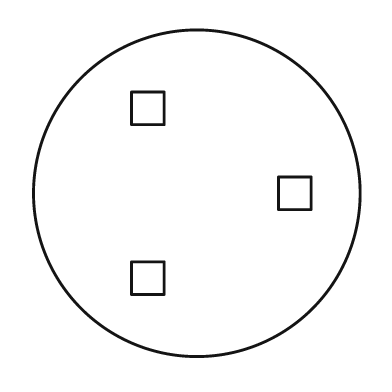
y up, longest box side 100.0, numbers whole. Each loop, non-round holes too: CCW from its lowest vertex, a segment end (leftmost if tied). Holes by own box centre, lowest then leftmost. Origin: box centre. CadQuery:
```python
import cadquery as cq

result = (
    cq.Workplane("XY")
    .moveTo(0.0, 0.0)
    .circle(50.0)
    .moveTo(-20.0, -31.0)
    .lineTo(-10.0, -31.0)
    .lineTo(-10.0, -21.0)
    .lineTo(-20.0, -21.0)
    .close()
    .moveTo(25.0, -5.0)
    .lineTo(35.0, -5.0)
    .lineTo(35.0, 5.0)
    .lineTo(25.0, 5.0)
    .close()
    .moveTo(-20.0, 21.0)
    .lineTo(-10.0, 21.0)
    .lineTo(-10.0, 31.0)
    .lineTo(-20.0, 31.0)
    .close()
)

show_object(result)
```